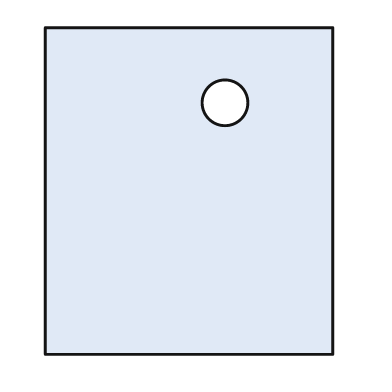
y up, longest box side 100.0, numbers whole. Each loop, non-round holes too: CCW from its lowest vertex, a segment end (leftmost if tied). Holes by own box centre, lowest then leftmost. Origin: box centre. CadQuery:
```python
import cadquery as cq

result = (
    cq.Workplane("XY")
    .moveTo(-44.0, -50.0)
    .lineTo(44.0, -50.0)
    .lineTo(44.0, 50.0)
    .lineTo(-44.0, 50.0)
    .close()
    .moveTo(11.0, 27.0)
    .circle(7.0)
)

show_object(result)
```